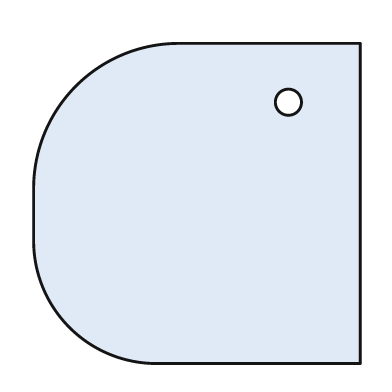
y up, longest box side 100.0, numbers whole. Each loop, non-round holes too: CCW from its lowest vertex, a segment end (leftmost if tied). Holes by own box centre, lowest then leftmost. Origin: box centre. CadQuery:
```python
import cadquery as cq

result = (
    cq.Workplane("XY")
    .moveTo(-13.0, -49.0)
    .lineTo(50.0, -49.0)
    .lineTo(50.0, 49.0)
    .lineTo(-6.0, 49.0)
    .threePointArc((-37.0, 36.0), (-50.0, 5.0))
    .lineTo(-50.0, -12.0)
    .threePointArc((-39.0, -38.0), (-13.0, -49.0))
    .close()
    .moveTo(28.0, 31.0)
    .circle(4.0)
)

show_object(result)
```